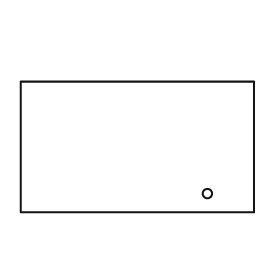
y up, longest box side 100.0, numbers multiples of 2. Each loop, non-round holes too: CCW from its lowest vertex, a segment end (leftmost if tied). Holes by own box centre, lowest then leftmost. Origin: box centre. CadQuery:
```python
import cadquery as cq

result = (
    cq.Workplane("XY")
    .moveTo(-50.0, -28.0)
    .lineTo(50.0, -28.0)
    .lineTo(50.0, 28.0)
    .lineTo(-50.0, 28.0)
    .close()
    .moveTo(30.0, -20.0)
    .circle(2.0)
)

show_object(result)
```